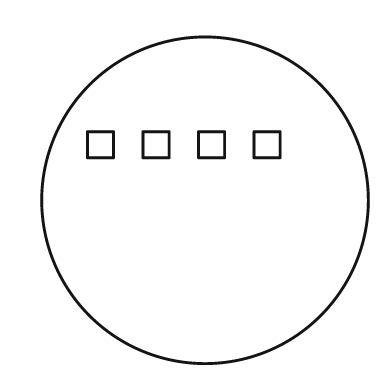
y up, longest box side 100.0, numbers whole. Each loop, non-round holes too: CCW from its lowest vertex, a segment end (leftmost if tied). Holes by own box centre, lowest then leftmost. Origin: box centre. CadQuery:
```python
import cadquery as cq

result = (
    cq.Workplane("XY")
    .moveTo(0.0, 0.0)
    .circle(50.0)
    .moveTo(-36.0, 13.0)
    .lineTo(-28.0, 13.0)
    .lineTo(-28.0, 21.0)
    .lineTo(-36.0, 21.0)
    .close()
    .moveTo(-19.0, 13.0)
    .lineTo(-11.0, 13.0)
    .lineTo(-11.0, 21.0)
    .lineTo(-19.0, 21.0)
    .close()
    .moveTo(-2.0, 13.0)
    .lineTo(6.0, 13.0)
    .lineTo(6.0, 21.0)
    .lineTo(-2.0, 21.0)
    .close()
    .moveTo(15.0, 13.0)
    .lineTo(23.0, 13.0)
    .lineTo(23.0, 21.0)
    .lineTo(15.0, 21.0)
    .close()
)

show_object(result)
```